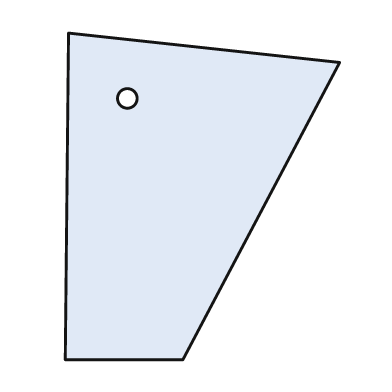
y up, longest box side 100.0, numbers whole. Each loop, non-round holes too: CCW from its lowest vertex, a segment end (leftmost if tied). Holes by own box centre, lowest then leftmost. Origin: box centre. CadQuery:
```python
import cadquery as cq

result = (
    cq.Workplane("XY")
    .moveTo(-42.0, -50.0)
    .lineTo(-6.0, -50.0)
    .lineTo(42.0, 41.0)
    .lineTo(-41.0, 50.0)
    .close()
    .moveTo(-23.0, 30.0)
    .circle(3.0)
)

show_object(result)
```